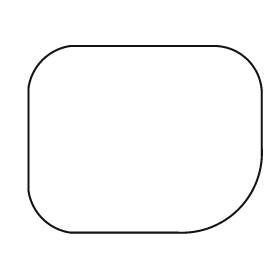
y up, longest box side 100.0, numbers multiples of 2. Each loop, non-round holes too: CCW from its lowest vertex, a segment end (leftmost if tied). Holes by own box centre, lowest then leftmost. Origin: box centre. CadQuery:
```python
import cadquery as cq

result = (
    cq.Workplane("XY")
    .moveTo(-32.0, -40.0)
    .lineTo(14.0, -40.0)
    .threePointArc((40.0, -30.0), (50.0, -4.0))
    .lineTo(50.0, 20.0)
    .threePointArc((44.0, 34.0), (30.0, 40.0))
    .lineTo(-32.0, 40.0)
    .threePointArc((-44.0, 34.0), (-50.0, 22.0))
    .lineTo(-50.0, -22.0)
    .threePointArc((-44.0, -34.0), (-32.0, -40.0))
    .close()
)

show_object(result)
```